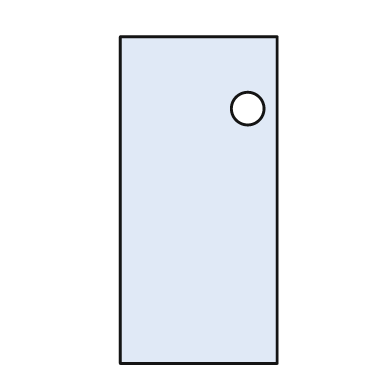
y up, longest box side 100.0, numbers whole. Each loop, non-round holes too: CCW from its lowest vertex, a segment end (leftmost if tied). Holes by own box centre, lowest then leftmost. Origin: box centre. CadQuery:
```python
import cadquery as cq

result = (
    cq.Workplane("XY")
    .moveTo(-24.0, -50.0)
    .lineTo(24.0, -50.0)
    .lineTo(24.0, 50.0)
    .lineTo(-24.0, 50.0)
    .close()
    .moveTo(15.0, 28.0)
    .circle(5.0)
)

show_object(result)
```